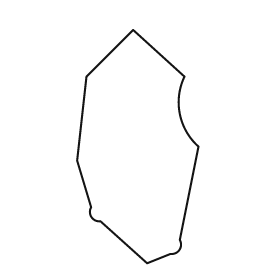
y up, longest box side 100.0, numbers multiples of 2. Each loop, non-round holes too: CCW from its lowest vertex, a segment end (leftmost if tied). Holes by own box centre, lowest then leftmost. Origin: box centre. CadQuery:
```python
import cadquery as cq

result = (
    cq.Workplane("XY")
    .moveTo(4.0, -50.0)
    .lineTo(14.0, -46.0)
    .threePointArc((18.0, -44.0), (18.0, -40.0))
    .lineTo(26.0, 0.0)
    .threePointArc((18.0, 14.0), (20.0, 30.0))
    .lineTo(-2.0, 50.0)
    .lineTo(-22.0, 30.0)
    .lineTo(-26.0, -6.0)
    .lineTo(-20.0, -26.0)
    .threePointArc((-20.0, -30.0), (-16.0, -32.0))
    .close()
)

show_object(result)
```